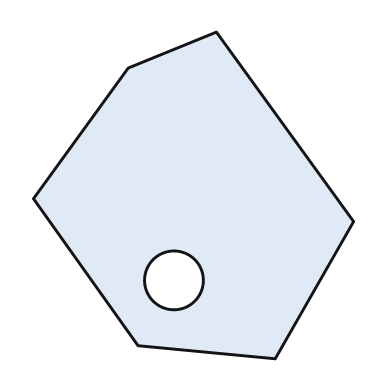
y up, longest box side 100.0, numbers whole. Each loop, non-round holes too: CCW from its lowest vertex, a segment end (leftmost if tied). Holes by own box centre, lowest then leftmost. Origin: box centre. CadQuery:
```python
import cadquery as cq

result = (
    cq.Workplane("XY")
    .moveTo(25.0, -50.0)
    .lineTo(49.0, -8.0)
    .lineTo(7.0, 50.0)
    .lineTo(-20.0, 39.0)
    .lineTo(-49.0, -1.0)
    .lineTo(-17.0, -46.0)
    .close()
    .moveTo(-6.0, -26.0)
    .circle(9.0)
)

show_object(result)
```